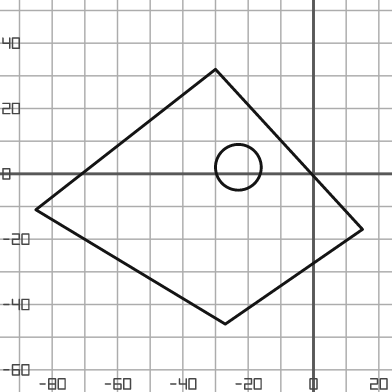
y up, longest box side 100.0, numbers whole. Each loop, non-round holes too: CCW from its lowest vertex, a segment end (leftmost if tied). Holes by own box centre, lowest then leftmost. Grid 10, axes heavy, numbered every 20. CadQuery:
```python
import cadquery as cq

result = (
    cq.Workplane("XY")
    .moveTo(-27.0, -46.0)
    .lineTo(15.0, -17.0)
    .lineTo(-30.0, 32.0)
    .lineTo(-85.0, -11.0)
    .close()
    .moveTo(-23.0, 2.0)
    .circle(7.0)
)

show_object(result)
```